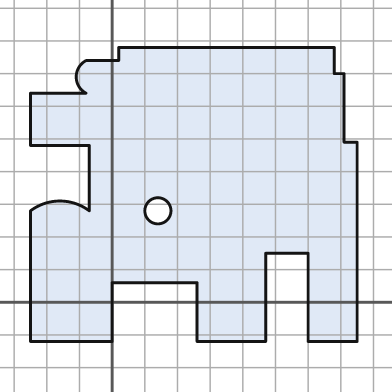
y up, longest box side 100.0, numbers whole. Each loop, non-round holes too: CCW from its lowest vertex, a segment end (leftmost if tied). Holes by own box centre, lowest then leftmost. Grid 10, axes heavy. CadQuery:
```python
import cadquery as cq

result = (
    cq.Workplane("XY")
    .moveTo(-25.0, -12.0)
    .lineTo(0.0, -12.0)
    .lineTo(0.0, 6.0)
    .lineTo(26.0, 6.0)
    .lineTo(26.0, -12.0)
    .lineTo(47.0, -12.0)
    .lineTo(47.0, 15.0)
    .lineTo(60.0, 15.0)
    .lineTo(60.0, -12.0)
    .lineTo(75.0, -12.0)
    .lineTo(75.0, 49.0)
    .lineTo(71.0, 49.0)
    .lineTo(71.0, 70.0)
    .lineTo(68.0, 70.0)
    .lineTo(68.0, 78.0)
    .lineTo(2.0, 78.0)
    .lineTo(2.0, 74.0)
    .lineTo(-8.0, 74.0)
    .threePointArc((-11.0, 69.0), (-8.0, 64.0))
    .lineTo(-25.0, 64.0)
    .lineTo(-25.0, 48.0)
    .lineTo(-7.0, 48.0)
    .lineTo(-7.0, 28.0)
    .threePointArc((-16.0, 31.0), (-25.0, 28.0))
    .close()
    .moveTo(14.0, 28.0)
    .circle(4.0)
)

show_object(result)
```